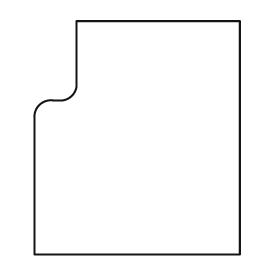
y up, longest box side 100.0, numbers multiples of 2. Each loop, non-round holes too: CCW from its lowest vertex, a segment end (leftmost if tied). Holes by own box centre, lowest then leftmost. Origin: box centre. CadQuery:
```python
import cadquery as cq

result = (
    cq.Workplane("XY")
    .moveTo(-44.0, -50.0)
    .lineTo(44.0, -50.0)
    .lineTo(44.0, 50.0)
    .lineTo(-26.0, 50.0)
    .lineTo(-26.0, 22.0)
    .threePointArc((-28.0, 18.0), (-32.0, 16.0))
    .lineTo(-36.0, 16.0)
    .threePointArc((-42.0, 14.0), (-44.0, 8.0))
    .close()
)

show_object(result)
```